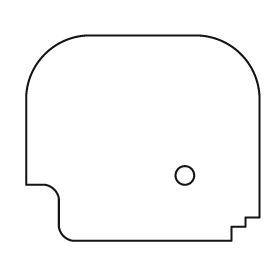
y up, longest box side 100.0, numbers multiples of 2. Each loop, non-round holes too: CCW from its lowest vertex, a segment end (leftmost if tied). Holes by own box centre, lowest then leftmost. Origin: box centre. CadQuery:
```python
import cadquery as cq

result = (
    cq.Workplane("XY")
    .moveTo(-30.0, -44.0)
    .lineTo(38.0, -44.0)
    .lineTo(38.0, -38.0)
    .lineTo(44.0, -38.0)
    .lineTo(44.0, -34.0)
    .lineTo(50.0, -34.0)
    .lineTo(50.0, 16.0)
    .threePointArc((42.0, 36.0), (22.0, 44.0))
    .lineTo(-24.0, 44.0)
    .threePointArc((-42.0, 36.0), (-50.0, 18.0))
    .lineTo(-50.0, -20.0)
    .lineTo(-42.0, -20.0)
    .threePointArc((-38.0, -22.0), (-36.0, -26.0))
    .lineTo(-36.0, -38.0)
    .threePointArc((-34.0, -42.0), (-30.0, -44.0))
    .close()
    .moveTo(18.0, -16.0)
    .circle(4.0)
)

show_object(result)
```